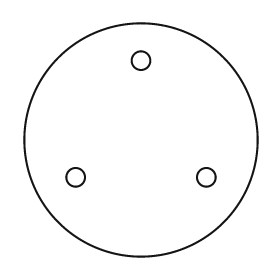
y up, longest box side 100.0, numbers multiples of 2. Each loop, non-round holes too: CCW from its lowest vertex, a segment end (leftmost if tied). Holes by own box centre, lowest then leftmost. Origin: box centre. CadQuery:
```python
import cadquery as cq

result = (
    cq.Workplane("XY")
    .moveTo(0.0, 0.0)
    .circle(50.0)
    .moveTo(-28.0, -16.0)
    .circle(4.0)
    .moveTo(28.0, -16.0)
    .circle(4.0)
    .moveTo(0.0, 34.0)
    .circle(4.0)
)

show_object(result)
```